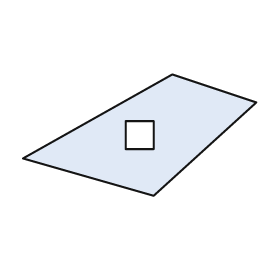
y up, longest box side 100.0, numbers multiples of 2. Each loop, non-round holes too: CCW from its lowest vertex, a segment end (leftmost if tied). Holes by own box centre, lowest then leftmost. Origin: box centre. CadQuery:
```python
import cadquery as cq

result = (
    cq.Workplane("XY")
    .moveTo(6.0, -26.0)
    .lineTo(50.0, 14.0)
    .lineTo(14.0, 26.0)
    .lineTo(-50.0, -10.0)
    .close()
    .moveTo(-6.0, -6.0)
    .lineTo(6.0, -6.0)
    .lineTo(6.0, 6.0)
    .lineTo(-6.0, 6.0)
    .close()
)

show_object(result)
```